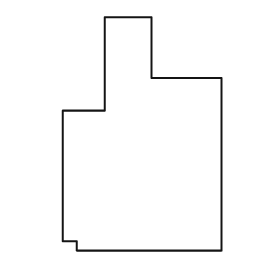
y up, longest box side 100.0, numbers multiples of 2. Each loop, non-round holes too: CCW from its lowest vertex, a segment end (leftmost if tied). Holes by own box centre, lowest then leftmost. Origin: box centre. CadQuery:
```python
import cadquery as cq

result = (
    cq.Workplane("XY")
    .moveTo(-28.0, -50.0)
    .lineTo(34.0, -50.0)
    .lineTo(34.0, 24.0)
    .lineTo(4.0, 24.0)
    .lineTo(4.0, 50.0)
    .lineTo(-16.0, 50.0)
    .lineTo(-16.0, 10.0)
    .lineTo(-34.0, 10.0)
    .lineTo(-34.0, -46.0)
    .lineTo(-28.0, -46.0)
    .close()
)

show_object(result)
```